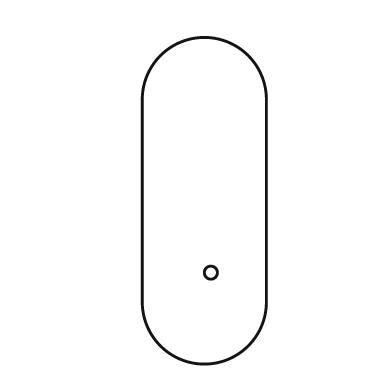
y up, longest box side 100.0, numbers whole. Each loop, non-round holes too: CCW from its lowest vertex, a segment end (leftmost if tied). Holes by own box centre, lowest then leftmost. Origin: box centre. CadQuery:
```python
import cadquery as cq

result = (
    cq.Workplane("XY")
    .moveTo(-19.0, -31.0)
    .threePointArc((0.0, -50.0), (19.0, -31.0))
    .lineTo(19.0, 31.0)
    .threePointArc((0.0, 50.0), (-19.0, 31.0))
    .close()
    .moveTo(2.0, -22.0)
    .circle(2.0)
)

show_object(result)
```